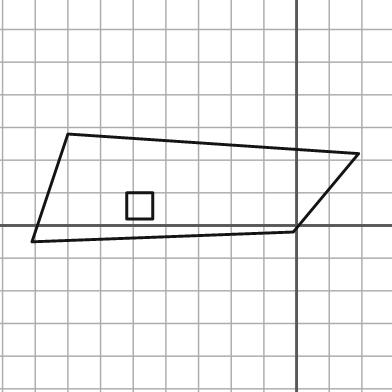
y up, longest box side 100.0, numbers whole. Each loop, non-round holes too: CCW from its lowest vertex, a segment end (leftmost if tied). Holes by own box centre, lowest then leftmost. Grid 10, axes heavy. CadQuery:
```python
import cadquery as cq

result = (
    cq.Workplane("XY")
    .moveTo(-81.0, -5.0)
    .lineTo(-1.0, -2.0)
    .lineTo(19.0, 22.0)
    .lineTo(-70.0, 28.0)
    .close()
    .moveTo(-52.0, 2.0)
    .lineTo(-44.0, 2.0)
    .lineTo(-44.0, 10.0)
    .lineTo(-52.0, 10.0)
    .close()
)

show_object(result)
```